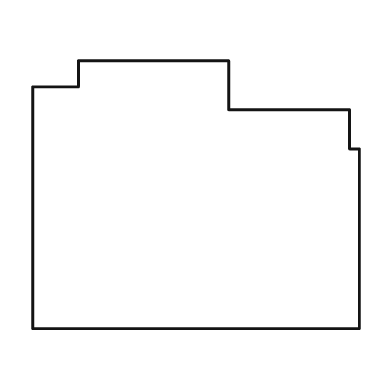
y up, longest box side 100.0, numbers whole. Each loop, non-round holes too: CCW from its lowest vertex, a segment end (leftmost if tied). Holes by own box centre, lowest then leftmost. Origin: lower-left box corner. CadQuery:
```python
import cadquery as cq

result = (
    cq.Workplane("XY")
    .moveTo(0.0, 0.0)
    .lineTo(100.0, 0.0)
    .lineTo(100.0, 55.0)
    .lineTo(97.0, 55.0)
    .lineTo(97.0, 67.0)
    .lineTo(60.0, 67.0)
    .lineTo(60.0, 82.0)
    .lineTo(14.0, 82.0)
    .lineTo(14.0, 74.0)
    .lineTo(0.0, 74.0)
    .close()
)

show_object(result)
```